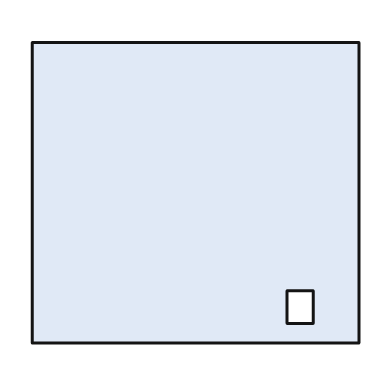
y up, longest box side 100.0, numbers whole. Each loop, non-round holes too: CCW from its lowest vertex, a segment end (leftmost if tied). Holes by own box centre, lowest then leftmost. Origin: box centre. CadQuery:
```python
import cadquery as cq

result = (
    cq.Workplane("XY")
    .moveTo(-50.0, -46.0)
    .lineTo(50.0, -46.0)
    .lineTo(50.0, 46.0)
    .lineTo(-50.0, 46.0)
    .close()
    .moveTo(28.0, -40.0)
    .lineTo(36.0, -40.0)
    .lineTo(36.0, -30.0)
    .lineTo(28.0, -30.0)
    .close()
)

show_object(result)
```